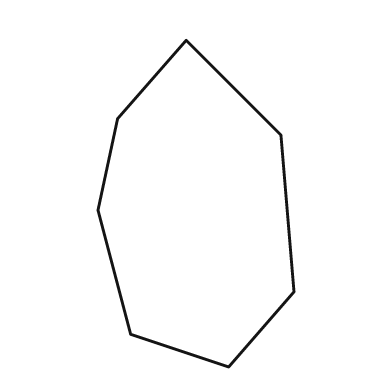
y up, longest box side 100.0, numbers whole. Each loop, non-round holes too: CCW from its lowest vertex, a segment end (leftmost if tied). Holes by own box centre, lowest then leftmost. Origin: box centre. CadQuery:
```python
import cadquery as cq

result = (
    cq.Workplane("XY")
    .moveTo(10.0, -50.0)
    .lineTo(30.0, -27.0)
    .lineTo(26.0, 21.0)
    .lineTo(-3.0, 50.0)
    .lineTo(-24.0, 26.0)
    .lineTo(-30.0, -2.0)
    .lineTo(-20.0, -40.0)
    .close()
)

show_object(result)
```